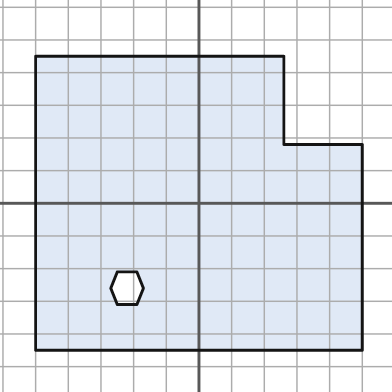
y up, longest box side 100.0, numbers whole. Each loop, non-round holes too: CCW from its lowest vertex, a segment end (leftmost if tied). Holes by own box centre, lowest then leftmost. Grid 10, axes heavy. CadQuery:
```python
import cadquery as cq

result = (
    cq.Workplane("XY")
    .moveTo(-50.0, -45.0)
    .lineTo(50.0, -45.0)
    .lineTo(50.0, 18.0)
    .lineTo(26.0, 18.0)
    .lineTo(26.0, 45.0)
    .lineTo(-50.0, 45.0)
    .close()
    .moveTo(-25.0, -31.0)
    .lineTo(-19.0, -31.0)
    .lineTo(-17.0, -26.0)
    .lineTo(-19.0, -21.0)
    .lineTo(-25.0, -21.0)
    .lineTo(-27.0, -26.0)
    .close()
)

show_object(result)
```